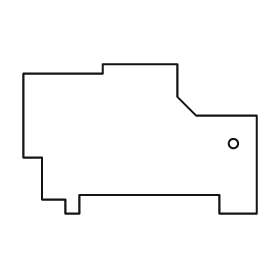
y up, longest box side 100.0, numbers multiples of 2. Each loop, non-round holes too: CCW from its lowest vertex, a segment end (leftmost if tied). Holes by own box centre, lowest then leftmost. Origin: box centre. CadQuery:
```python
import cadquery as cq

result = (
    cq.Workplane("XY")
    .moveTo(-32.0, -32.0)
    .lineTo(-26.0, -32.0)
    .lineTo(-26.0, -24.0)
    .lineTo(34.0, -24.0)
    .lineTo(34.0, -32.0)
    .lineTo(50.0, -32.0)
    .lineTo(50.0, 10.0)
    .lineTo(24.0, 10.0)
    .lineTo(16.0, 18.0)
    .lineTo(16.0, 32.0)
    .lineTo(-16.0, 32.0)
    .lineTo(-16.0, 28.0)
    .lineTo(-50.0, 28.0)
    .lineTo(-50.0, -8.0)
    .lineTo(-42.0, -8.0)
    .lineTo(-42.0, -26.0)
    .lineTo(-32.0, -26.0)
    .close()
    .moveTo(40.0, -2.0)
    .circle(2.0)
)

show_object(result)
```